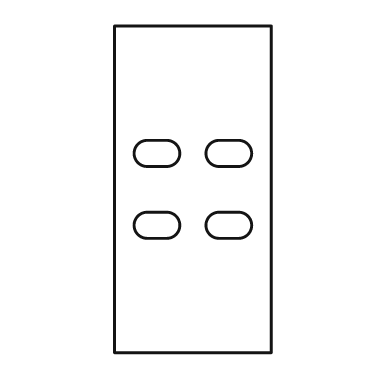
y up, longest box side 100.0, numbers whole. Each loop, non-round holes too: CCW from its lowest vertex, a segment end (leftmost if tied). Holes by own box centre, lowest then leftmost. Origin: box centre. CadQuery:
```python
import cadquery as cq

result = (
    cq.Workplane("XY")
    .moveTo(-24.0, -50.0)
    .lineTo(24.0, -50.0)
    .lineTo(24.0, 50.0)
    .lineTo(-24.0, 50.0)
    .close()
    .moveTo(-14.0, -15.0)
    .lineTo(-8.0, -15.0)
    .threePointArc((-4.0, -11.0), (-8.0, -7.0))
    .lineTo(-14.0, -7.0)
    .threePointArc((-18.0, -11.0), (-14.0, -15.0))
    .close()
    .moveTo(8.0, -15.0)
    .lineTo(14.0, -15.0)
    .threePointArc((18.0, -11.0), (14.0, -7.0))
    .lineTo(8.0, -7.0)
    .threePointArc((4.0, -11.0), (8.0, -15.0))
    .close()
    .moveTo(-14.0, 7.0)
    .lineTo(-8.0, 7.0)
    .threePointArc((-4.0, 11.0), (-8.0, 15.0))
    .lineTo(-14.0, 15.0)
    .threePointArc((-18.0, 11.0), (-14.0, 7.0))
    .close()
    .moveTo(8.0, 7.0)
    .lineTo(14.0, 7.0)
    .threePointArc((18.0, 11.0), (14.0, 15.0))
    .lineTo(8.0, 15.0)
    .threePointArc((4.0, 11.0), (8.0, 7.0))
    .close()
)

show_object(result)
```